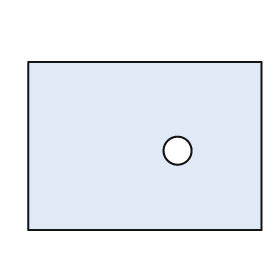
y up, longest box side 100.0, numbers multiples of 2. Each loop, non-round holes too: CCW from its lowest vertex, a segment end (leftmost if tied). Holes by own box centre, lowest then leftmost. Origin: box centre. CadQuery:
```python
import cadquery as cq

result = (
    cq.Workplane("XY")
    .moveTo(-50.0, -36.0)
    .lineTo(50.0, -36.0)
    .lineTo(50.0, 36.0)
    .lineTo(-50.0, 36.0)
    .close()
    .moveTo(14.0, -2.0)
    .circle(6.0)
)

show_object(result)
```